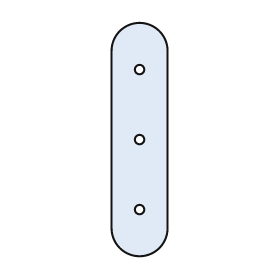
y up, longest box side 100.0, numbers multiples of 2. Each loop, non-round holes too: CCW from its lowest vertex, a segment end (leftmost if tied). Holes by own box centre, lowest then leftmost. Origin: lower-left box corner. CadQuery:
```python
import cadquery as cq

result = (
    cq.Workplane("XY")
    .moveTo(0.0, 12.0)
    .threePointArc((12.0, 0.0), (24.0, 12.0))
    .lineTo(24.0, 88.0)
    .threePointArc((12.0, 100.0), (0.0, 88.0))
    .close()
    .moveTo(12.0, 20.0)
    .circle(2.0)
    .moveTo(12.0, 50.0)
    .circle(2.0)
    .moveTo(12.0, 80.0)
    .circle(2.0)
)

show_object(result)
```